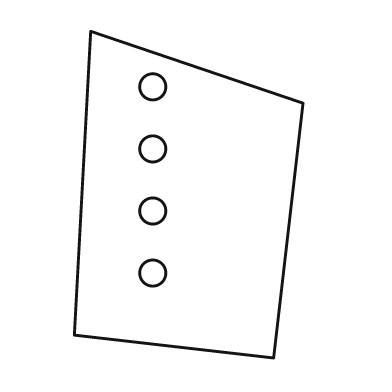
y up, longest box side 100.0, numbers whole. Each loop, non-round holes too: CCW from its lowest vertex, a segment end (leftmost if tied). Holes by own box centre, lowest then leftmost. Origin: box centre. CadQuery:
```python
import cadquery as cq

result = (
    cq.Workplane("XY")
    .moveTo(26.0, -50.0)
    .lineTo(35.0, 28.0)
    .lineTo(-30.0, 50.0)
    .lineTo(-35.0, -43.0)
    .close()
    .moveTo(-11.0, -24.0)
    .circle(4.0)
    .moveTo(-11.0, -5.0)
    .circle(4.0)
    .moveTo(-11.0, 14.0)
    .circle(4.0)
    .moveTo(-11.0, 33.0)
    .circle(4.0)
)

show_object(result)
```